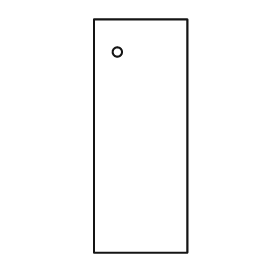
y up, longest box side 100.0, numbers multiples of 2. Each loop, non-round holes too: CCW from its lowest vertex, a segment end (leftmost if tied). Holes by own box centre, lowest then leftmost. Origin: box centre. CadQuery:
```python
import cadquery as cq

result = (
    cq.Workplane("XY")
    .moveTo(-20.0, -50.0)
    .lineTo(20.0, -50.0)
    .lineTo(20.0, 50.0)
    .lineTo(-20.0, 50.0)
    .close()
    .moveTo(-10.0, 36.0)
    .circle(2.0)
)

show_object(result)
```